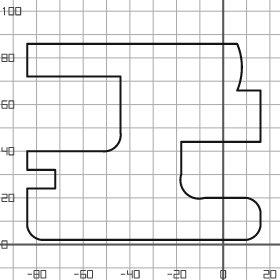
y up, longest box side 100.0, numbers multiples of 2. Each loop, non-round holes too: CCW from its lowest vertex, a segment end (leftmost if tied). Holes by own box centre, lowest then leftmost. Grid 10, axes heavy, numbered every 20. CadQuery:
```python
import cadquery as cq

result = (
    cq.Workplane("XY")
    .moveTo(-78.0, 2.0)
    .lineTo(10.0, 2.0)
    .threePointArc((14.0, 4.0), (16.0, 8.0))
    .lineTo(16.0, 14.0)
    .threePointArc((14.0, 18.0), (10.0, 20.0))
    .lineTo(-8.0, 20.0)
    .threePointArc((-16.0, 22.0), (-18.0, 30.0))
    .lineTo(-18.0, 44.0)
    .lineTo(16.0, 44.0)
    .lineTo(16.0, 66.0)
    .lineTo(6.0, 66.0)
    .threePointArc((8.0, 76.0), (6.0, 86.0))
    .lineTo(-84.0, 86.0)
    .lineTo(-84.0, 72.0)
    .lineTo(-44.0, 72.0)
    .lineTo(-44.0, 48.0)
    .threePointArc((-46.0, 42.0), (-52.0, 40.0))
    .lineTo(-84.0, 40.0)
    .lineTo(-84.0, 32.0)
    .lineTo(-72.0, 32.0)
    .lineTo(-72.0, 24.0)
    .lineTo(-84.0, 24.0)
    .lineTo(-84.0, 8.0)
    .threePointArc((-82.0, 4.0), (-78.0, 2.0))
    .close()
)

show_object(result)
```